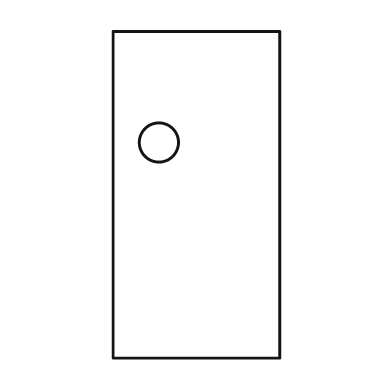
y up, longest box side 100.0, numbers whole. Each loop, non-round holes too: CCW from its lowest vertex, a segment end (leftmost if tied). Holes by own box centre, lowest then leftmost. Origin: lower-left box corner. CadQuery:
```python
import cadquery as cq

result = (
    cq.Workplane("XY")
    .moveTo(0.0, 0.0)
    .lineTo(51.0, 0.0)
    .lineTo(51.0, 100.0)
    .lineTo(0.0, 100.0)
    .close()
    .moveTo(14.0, 66.0)
    .circle(6.0)
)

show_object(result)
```